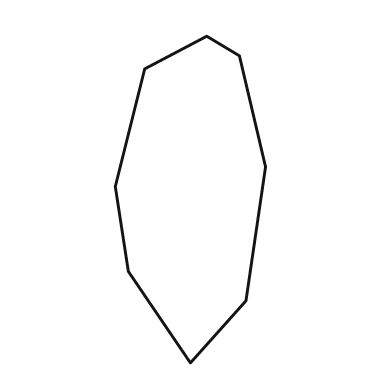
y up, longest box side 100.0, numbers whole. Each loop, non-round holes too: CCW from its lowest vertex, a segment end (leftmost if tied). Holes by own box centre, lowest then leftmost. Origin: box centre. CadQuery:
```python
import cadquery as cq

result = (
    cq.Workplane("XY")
    .moveTo(0.0, -50.0)
    .lineTo(17.0, -31.0)
    .lineTo(23.0, 10.0)
    .lineTo(15.0, 44.0)
    .lineTo(5.0, 50.0)
    .lineTo(-14.0, 40.0)
    .lineTo(-23.0, 4.0)
    .lineTo(-19.0, -22.0)
    .close()
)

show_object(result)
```